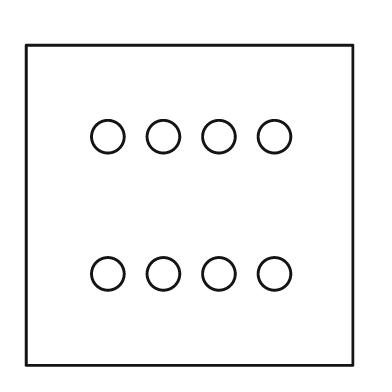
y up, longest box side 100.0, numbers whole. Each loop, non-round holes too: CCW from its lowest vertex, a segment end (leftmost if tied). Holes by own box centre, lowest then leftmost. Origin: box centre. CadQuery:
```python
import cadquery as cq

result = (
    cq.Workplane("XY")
    .moveTo(-50.0, -49.0)
    .lineTo(50.0, -49.0)
    .lineTo(50.0, 49.0)
    .lineTo(-50.0, 49.0)
    .close()
    .moveTo(-25.0, -21.0)
    .circle(5.0)
    .moveTo(-8.0, -21.0)
    .circle(5.0)
    .moveTo(9.0, -21.0)
    .circle(5.0)
    .moveTo(26.0, -21.0)
    .circle(5.0)
    .moveTo(-25.0, 21.0)
    .circle(5.0)
    .moveTo(-8.0, 21.0)
    .circle(5.0)
    .moveTo(9.0, 21.0)
    .circle(5.0)
    .moveTo(26.0, 21.0)
    .circle(5.0)
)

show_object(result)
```